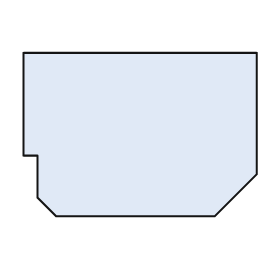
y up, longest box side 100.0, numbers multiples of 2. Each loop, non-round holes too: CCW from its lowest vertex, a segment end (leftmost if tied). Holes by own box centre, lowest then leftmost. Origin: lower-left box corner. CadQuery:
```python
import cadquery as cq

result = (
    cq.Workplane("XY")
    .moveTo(14.0, 0.0)
    .lineTo(82.0, 0.0)
    .lineTo(100.0, 18.0)
    .lineTo(100.0, 70.0)
    .lineTo(0.0, 70.0)
    .lineTo(0.0, 26.0)
    .lineTo(6.0, 26.0)
    .lineTo(6.0, 8.0)
    .close()
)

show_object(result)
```